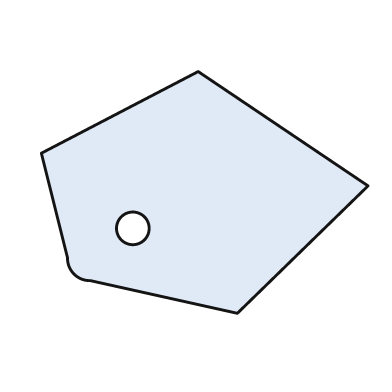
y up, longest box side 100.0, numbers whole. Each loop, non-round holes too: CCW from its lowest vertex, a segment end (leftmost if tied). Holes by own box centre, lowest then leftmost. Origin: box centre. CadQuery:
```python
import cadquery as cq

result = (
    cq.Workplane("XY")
    .moveTo(10.0, -37.0)
    .lineTo(50.0, 2.0)
    .lineTo(-2.0, 37.0)
    .lineTo(-50.0, 12.0)
    .lineTo(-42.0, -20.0)
    .threePointArc((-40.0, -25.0), (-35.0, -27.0))
    .close()
    .moveTo(-22.0, -11.0)
    .circle(5.0)
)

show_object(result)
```